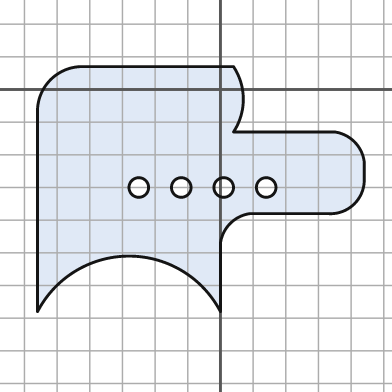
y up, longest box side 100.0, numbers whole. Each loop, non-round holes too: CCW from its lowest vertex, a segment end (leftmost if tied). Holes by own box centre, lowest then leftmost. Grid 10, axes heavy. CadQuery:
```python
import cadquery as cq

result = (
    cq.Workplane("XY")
    .moveTo(-56.0, -68.0)
    .threePointArc((-28.0, -51.0), (0.0, -68.0))
    .lineTo(0.0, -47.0)
    .threePointArc((3.0, -41.0), (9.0, -38.0))
    .lineTo(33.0, -38.0)
    .threePointArc((41.0, -35.0), (44.0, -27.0))
    .lineTo(44.0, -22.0)
    .threePointArc((41.0, -16.0), (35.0, -13.0))
    .lineTo(4.0, -13.0)
    .threePointArc((7.0, -3.0), (4.0, 7.0))
    .lineTo(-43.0, 7.0)
    .threePointArc((-52.0, 3.0), (-56.0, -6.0))
    .close()
    .moveTo(-25.0, -30.0)
    .circle(3.0)
    .moveTo(-12.0, -30.0)
    .circle(3.0)
    .moveTo(1.0, -30.0)
    .circle(3.0)
    .moveTo(14.0, -30.0)
    .circle(3.0)
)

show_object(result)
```